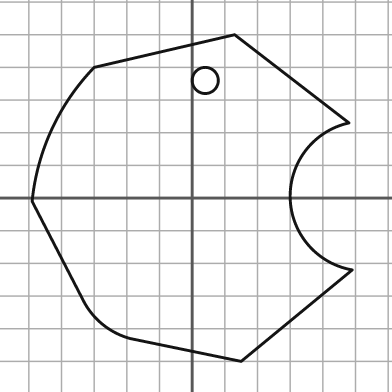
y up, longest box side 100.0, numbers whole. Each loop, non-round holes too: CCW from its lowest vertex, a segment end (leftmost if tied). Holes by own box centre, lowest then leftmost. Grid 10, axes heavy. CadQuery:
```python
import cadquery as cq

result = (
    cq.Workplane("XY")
    .moveTo(15.0, -50.0)
    .lineTo(49.0, -22.0)
    .threePointArc((30.0, 0.0), (48.0, 23.0))
    .lineTo(13.0, 50.0)
    .lineTo(-30.0, 40.0)
    .threePointArc((-43.0, 21.0), (-49.0, -1.0))
    .lineTo(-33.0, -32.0)
    .threePointArc((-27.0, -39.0), (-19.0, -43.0))
    .close()
    .moveTo(4.0, 36.0)
    .circle(4.0)
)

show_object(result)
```